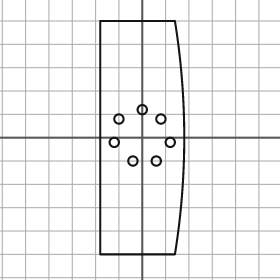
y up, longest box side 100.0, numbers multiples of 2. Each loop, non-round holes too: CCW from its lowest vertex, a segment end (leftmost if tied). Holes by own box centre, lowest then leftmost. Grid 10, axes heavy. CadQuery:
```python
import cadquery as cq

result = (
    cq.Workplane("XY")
    .moveTo(-18.0, -50.0)
    .lineTo(14.0, -50.0)
    .threePointArc((18.0, 0.0), (14.0, 50.0))
    .lineTo(-18.0, 50.0)
    .close()
    .moveTo(-4.0, -10.0)
    .circle(2.0)
    .moveTo(6.0, -10.0)
    .circle(2.0)
    .moveTo(-12.0, -2.0)
    .circle(2.0)
    .moveTo(12.0, -2.0)
    .circle(2.0)
    .moveTo(-10.0, 8.0)
    .circle(2.0)
    .moveTo(8.0, 8.0)
    .circle(2.0)
    .moveTo(0.0, 12.0)
    .circle(2.0)
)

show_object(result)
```